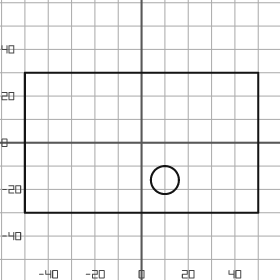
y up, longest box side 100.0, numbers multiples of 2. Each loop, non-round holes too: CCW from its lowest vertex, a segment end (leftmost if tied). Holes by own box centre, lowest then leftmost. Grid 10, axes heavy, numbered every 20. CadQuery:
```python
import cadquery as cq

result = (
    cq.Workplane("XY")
    .moveTo(-50.0, -30.0)
    .lineTo(50.0, -30.0)
    .lineTo(50.0, 30.0)
    .lineTo(-50.0, 30.0)
    .close()
    .moveTo(10.0, -16.0)
    .circle(6.0)
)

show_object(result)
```